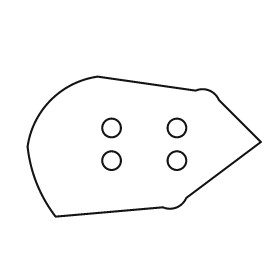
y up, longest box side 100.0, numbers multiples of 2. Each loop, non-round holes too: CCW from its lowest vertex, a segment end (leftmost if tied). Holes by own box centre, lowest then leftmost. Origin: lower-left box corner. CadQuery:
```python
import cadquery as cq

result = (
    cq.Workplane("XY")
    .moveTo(12.0, 0.0)
    .lineTo(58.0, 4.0)
    .threePointArc((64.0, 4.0), (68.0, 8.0))
    .lineTo(100.0, 32.0)
    .lineTo(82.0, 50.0)
    .threePointArc((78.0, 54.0), (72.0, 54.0))
    .lineTo(30.0, 60.0)
    .threePointArc((10.0, 50.0), (0.0, 30.0))
    .threePointArc((4.0, 14.0), (12.0, 0.0))
    .close()
    .moveTo(36.0, 24.0)
    .circle(4.0)
    .moveTo(64.0, 24.0)
    .circle(4.0)
    .moveTo(36.0, 38.0)
    .circle(4.0)
    .moveTo(64.0, 38.0)
    .circle(4.0)
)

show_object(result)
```